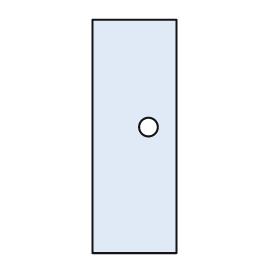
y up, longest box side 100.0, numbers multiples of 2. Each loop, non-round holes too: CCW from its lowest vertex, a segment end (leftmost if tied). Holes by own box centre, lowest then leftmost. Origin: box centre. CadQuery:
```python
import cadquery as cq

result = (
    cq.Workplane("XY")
    .moveTo(-18.0, -50.0)
    .lineTo(18.0, -50.0)
    .lineTo(18.0, 50.0)
    .lineTo(-18.0, 50.0)
    .close()
    .moveTo(6.0, 4.0)
    .circle(4.0)
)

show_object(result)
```